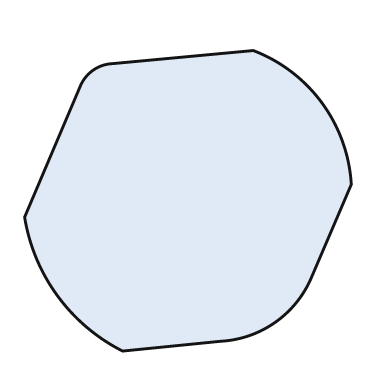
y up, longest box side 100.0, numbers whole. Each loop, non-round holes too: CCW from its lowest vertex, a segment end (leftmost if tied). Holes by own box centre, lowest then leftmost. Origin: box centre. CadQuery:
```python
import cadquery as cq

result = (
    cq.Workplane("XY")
    .moveTo(-20.0, -46.0)
    .lineTo(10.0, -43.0)
    .threePointArc((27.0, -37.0), (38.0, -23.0))
    .lineTo(50.0, 5.0)
    .threePointArc((41.0, 30.0), (20.0, 46.0))
    .lineTo(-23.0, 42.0)
    .threePointArc((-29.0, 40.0), (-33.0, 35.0))
    .lineTo(-50.0, -5.0)
    .threePointArc((-40.0, -29.0), (-20.0, -46.0))
    .close()
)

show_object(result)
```